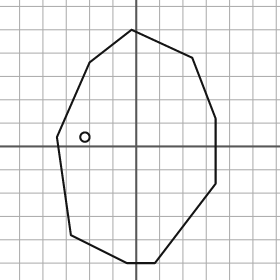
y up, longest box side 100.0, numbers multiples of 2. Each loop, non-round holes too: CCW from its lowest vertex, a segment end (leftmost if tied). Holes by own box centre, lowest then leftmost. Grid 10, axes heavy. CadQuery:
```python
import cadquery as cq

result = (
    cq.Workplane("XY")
    .moveTo(-4.0, -50.0)
    .lineTo(8.0, -50.0)
    .lineTo(34.0, -16.0)
    .lineTo(34.0, 12.0)
    .lineTo(24.0, 38.0)
    .lineTo(-2.0, 50.0)
    .lineTo(-20.0, 36.0)
    .lineTo(-34.0, 4.0)
    .lineTo(-28.0, -38.0)
    .close()
    .moveTo(-22.0, 4.0)
    .circle(2.0)
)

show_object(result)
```